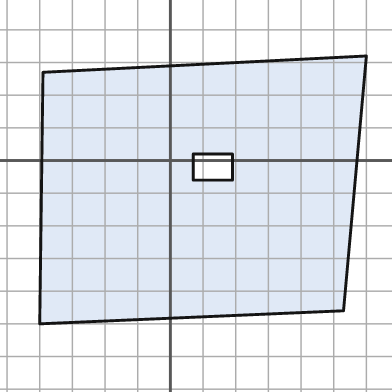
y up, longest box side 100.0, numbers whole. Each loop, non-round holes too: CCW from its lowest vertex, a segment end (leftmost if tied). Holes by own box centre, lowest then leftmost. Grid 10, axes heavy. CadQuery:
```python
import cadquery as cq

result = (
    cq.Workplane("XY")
    .moveTo(-40.0, -50.0)
    .lineTo(53.0, -46.0)
    .lineTo(60.0, 32.0)
    .lineTo(-39.0, 27.0)
    .close()
    .moveTo(7.0, -6.0)
    .lineTo(19.0, -6.0)
    .lineTo(19.0, 2.0)
    .lineTo(7.0, 2.0)
    .close()
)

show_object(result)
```